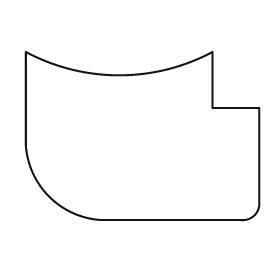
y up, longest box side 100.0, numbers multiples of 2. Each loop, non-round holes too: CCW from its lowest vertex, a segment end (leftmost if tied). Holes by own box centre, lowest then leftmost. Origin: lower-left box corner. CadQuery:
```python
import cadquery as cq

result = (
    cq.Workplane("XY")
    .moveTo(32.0, 0.0)
    .lineTo(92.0, 0.0)
    .threePointArc((98.0, 2.0), (100.0, 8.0))
    .lineTo(100.0, 48.0)
    .lineTo(80.0, 48.0)
    .lineTo(80.0, 72.0)
    .threePointArc((40.0, 62.0), (0.0, 72.0))
    .lineTo(0.0, 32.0)
    .threePointArc((10.0, 10.0), (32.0, 0.0))
    .close()
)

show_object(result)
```